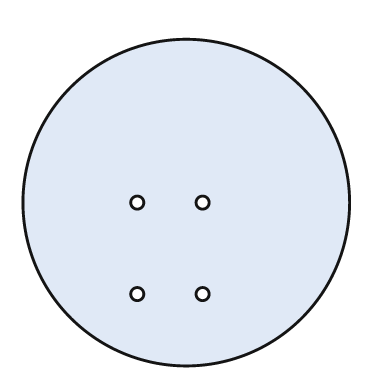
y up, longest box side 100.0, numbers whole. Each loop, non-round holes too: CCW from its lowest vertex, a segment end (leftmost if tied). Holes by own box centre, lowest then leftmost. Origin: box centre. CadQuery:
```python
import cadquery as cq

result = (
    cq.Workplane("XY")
    .moveTo(0.0, 0.0)
    .circle(50.0)
    .moveTo(-15.0, -28.0)
    .circle(2.0)
    .moveTo(5.0, -28.0)
    .circle(2.0)
    .moveTo(-15.0, 0.0)
    .circle(2.0)
    .moveTo(5.0, 0.0)
    .circle(2.0)
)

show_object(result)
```